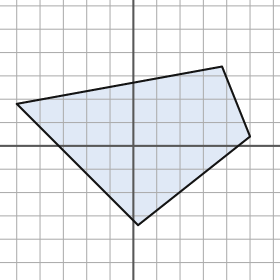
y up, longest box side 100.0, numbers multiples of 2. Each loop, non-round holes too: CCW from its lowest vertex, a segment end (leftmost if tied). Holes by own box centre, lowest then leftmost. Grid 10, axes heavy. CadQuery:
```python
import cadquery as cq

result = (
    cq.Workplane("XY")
    .moveTo(2.0, -34.0)
    .lineTo(50.0, 4.0)
    .lineTo(38.0, 34.0)
    .lineTo(-50.0, 18.0)
    .close()
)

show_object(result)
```